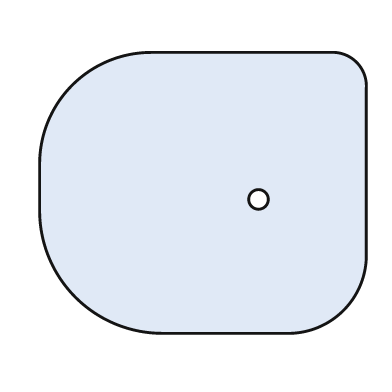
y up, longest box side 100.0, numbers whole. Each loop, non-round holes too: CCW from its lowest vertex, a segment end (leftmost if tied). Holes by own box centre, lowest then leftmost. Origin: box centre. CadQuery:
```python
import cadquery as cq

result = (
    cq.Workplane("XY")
    .moveTo(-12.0, -43.0)
    .lineTo(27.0, -43.0)
    .threePointArc((43.0, -36.0), (50.0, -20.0))
    .lineTo(50.0, 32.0)
    .threePointArc((47.0, 40.0), (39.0, 43.0))
    .lineTo(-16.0, 43.0)
    .threePointArc((-40.0, 33.0), (-50.0, 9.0))
    .lineTo(-50.0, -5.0)
    .threePointArc((-39.0, -32.0), (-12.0, -43.0))
    .close()
    .moveTo(17.0, -2.0)
    .circle(3.0)
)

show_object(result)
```